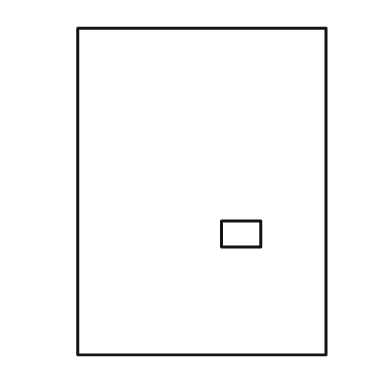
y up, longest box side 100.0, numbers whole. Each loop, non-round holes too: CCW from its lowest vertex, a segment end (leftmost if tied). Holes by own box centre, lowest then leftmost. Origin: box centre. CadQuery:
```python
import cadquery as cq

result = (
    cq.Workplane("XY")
    .moveTo(-38.0, -50.0)
    .lineTo(38.0, -50.0)
    .lineTo(38.0, 50.0)
    .lineTo(-38.0, 50.0)
    .close()
    .moveTo(6.0, -17.0)
    .lineTo(18.0, -17.0)
    .lineTo(18.0, -9.0)
    .lineTo(6.0, -9.0)
    .close()
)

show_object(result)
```